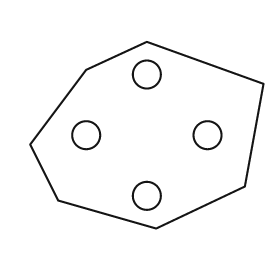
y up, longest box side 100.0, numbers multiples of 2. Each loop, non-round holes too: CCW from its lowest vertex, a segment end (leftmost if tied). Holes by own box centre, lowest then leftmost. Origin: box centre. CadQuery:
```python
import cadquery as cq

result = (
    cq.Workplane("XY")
    .moveTo(4.0, -40.0)
    .lineTo(42.0, -22.0)
    .lineTo(50.0, 22.0)
    .lineTo(0.0, 40.0)
    .lineTo(-26.0, 28.0)
    .lineTo(-50.0, -4.0)
    .lineTo(-38.0, -28.0)
    .close()
    .moveTo(0.0, -26.0)
    .circle(6.0)
    .moveTo(-26.0, 0.0)
    .circle(6.0)
    .moveTo(26.0, 0.0)
    .circle(6.0)
    .moveTo(0.0, 26.0)
    .circle(6.0)
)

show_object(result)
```